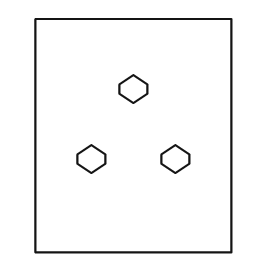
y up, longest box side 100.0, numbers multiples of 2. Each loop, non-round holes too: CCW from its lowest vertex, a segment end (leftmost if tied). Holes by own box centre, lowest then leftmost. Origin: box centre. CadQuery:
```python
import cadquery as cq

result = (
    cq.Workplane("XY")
    .moveTo(-42.0, -50.0)
    .lineTo(42.0, -50.0)
    .lineTo(42.0, 50.0)
    .lineTo(-42.0, 50.0)
    .close()
    .moveTo(-18.0, -16.0)
    .lineTo(-12.0, -12.0)
    .lineTo(-12.0, -8.0)
    .lineTo(-18.0, -4.0)
    .lineTo(-24.0, -8.0)
    .lineTo(-24.0, -12.0)
    .close()
    .moveTo(18.0, -16.0)
    .lineTo(24.0, -12.0)
    .lineTo(24.0, -8.0)
    .lineTo(18.0, -4.0)
    .lineTo(12.0, -8.0)
    .lineTo(12.0, -12.0)
    .close()
    .moveTo(0.0, 14.0)
    .lineTo(6.0, 18.0)
    .lineTo(6.0, 22.0)
    .lineTo(0.0, 26.0)
    .lineTo(-6.0, 22.0)
    .lineTo(-6.0, 18.0)
    .close()
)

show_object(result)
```